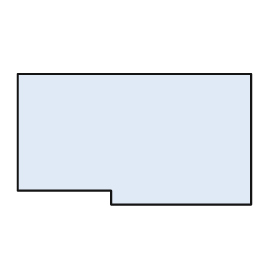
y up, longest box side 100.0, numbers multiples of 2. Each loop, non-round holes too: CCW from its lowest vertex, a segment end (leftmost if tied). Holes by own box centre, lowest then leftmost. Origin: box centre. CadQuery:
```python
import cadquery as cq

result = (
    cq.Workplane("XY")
    .moveTo(-10.0, -28.0)
    .lineTo(50.0, -28.0)
    .lineTo(50.0, 28.0)
    .lineTo(-50.0, 28.0)
    .lineTo(-50.0, -22.0)
    .lineTo(-10.0, -22.0)
    .close()
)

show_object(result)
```